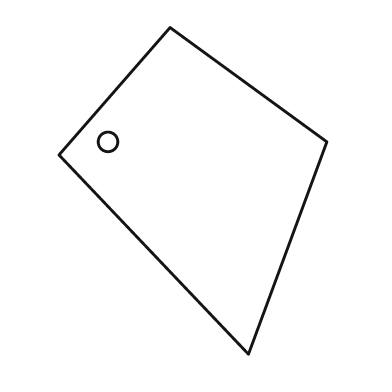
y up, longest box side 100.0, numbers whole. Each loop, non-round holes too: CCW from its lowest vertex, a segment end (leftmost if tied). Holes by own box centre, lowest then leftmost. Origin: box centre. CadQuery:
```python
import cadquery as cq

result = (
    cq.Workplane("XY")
    .moveTo(17.0, -50.0)
    .lineTo(41.0, 15.0)
    .lineTo(-7.0, 50.0)
    .lineTo(-41.0, 11.0)
    .close()
    .moveTo(-26.0, 15.0)
    .circle(3.0)
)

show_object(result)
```